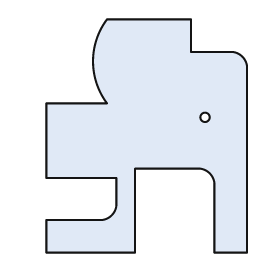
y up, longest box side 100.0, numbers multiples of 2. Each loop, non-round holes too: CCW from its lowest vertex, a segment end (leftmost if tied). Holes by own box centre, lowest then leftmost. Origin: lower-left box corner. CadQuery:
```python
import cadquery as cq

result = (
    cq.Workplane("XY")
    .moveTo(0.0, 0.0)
    .lineTo(38.0, 0.0)
    .lineTo(38.0, 36.0)
    .lineTo(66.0, 36.0)
    .threePointArc((70.0, 34.0), (72.0, 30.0))
    .lineTo(72.0, 0.0)
    .lineTo(86.0, 0.0)
    .lineTo(86.0, 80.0)
    .threePointArc((84.0, 84.0), (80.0, 86.0))
    .lineTo(62.0, 86.0)
    .lineTo(62.0, 100.0)
    .lineTo(26.0, 100.0)
    .threePointArc((20.0, 82.0), (26.0, 64.0))
    .lineTo(0.0, 64.0)
    .lineTo(0.0, 32.0)
    .lineTo(30.0, 32.0)
    .lineTo(30.0, 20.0)
    .threePointArc((28.0, 16.0), (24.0, 14.0))
    .lineTo(0.0, 14.0)
    .close()
    .moveTo(68.0, 58.0)
    .circle(2.0)
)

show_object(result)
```